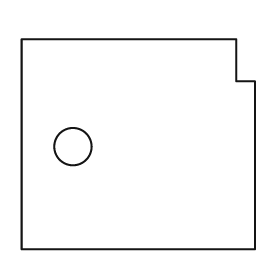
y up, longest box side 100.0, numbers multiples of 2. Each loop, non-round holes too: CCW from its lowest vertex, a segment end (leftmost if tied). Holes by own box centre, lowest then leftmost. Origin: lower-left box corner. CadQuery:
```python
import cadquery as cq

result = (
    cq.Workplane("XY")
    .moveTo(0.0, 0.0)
    .lineTo(100.0, 0.0)
    .lineTo(100.0, 72.0)
    .lineTo(92.0, 72.0)
    .lineTo(92.0, 90.0)
    .lineTo(0.0, 90.0)
    .close()
    .moveTo(22.0, 44.0)
    .circle(8.0)
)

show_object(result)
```